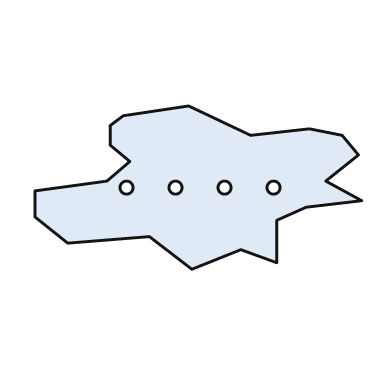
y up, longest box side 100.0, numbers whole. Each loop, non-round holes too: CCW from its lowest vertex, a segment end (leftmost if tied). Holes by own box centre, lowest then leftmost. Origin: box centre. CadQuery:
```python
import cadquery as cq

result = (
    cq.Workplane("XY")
    .moveTo(-2.0, -25.0)
    .lineTo(13.0, -19.0)
    .lineTo(24.0, -23.0)
    .lineTo(24.0, -10.0)
    .lineTo(33.0, -6.0)
    .lineTo(50.0, -4.0)
    .lineTo(39.0, 2.0)
    .lineTo(49.0, 10.0)
    .lineTo(44.0, 16.0)
    .lineTo(34.0, 18.0)
    .lineTo(16.0, 16.0)
    .lineTo(-3.0, 25.0)
    .lineTo(-23.0, 22.0)
    .lineTo(-27.0, 19.0)
    .lineTo(-27.0, 13.0)
    .lineTo(-21.0, 8.0)
    .lineTo(-28.0, 2.0)
    .lineTo(-50.0, -1.0)
    .lineTo(-50.0, -9.0)
    .lineTo(-40.0, -17.0)
    .lineTo(-15.0, -15.0)
    .close()
    .moveTo(-22.0, 0.0)
    .circle(2.0)
    .moveTo(-7.0, 0.0)
    .circle(2.0)
    .moveTo(8.0, 0.0)
    .circle(2.0)
    .moveTo(23.0, 0.0)
    .circle(2.0)
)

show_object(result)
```